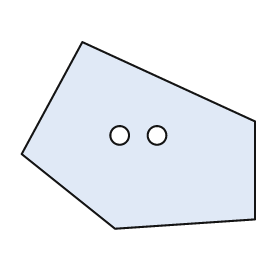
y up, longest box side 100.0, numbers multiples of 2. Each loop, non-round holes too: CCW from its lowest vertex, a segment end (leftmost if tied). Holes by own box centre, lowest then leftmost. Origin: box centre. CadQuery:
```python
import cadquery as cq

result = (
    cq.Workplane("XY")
    .moveTo(-10.0, -40.0)
    .lineTo(50.0, -36.0)
    .lineTo(50.0, 6.0)
    .lineTo(-24.0, 40.0)
    .lineTo(-50.0, -8.0)
    .close()
    .moveTo(-8.0, 0.0)
    .circle(4.0)
    .moveTo(8.0, 0.0)
    .circle(4.0)
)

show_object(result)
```